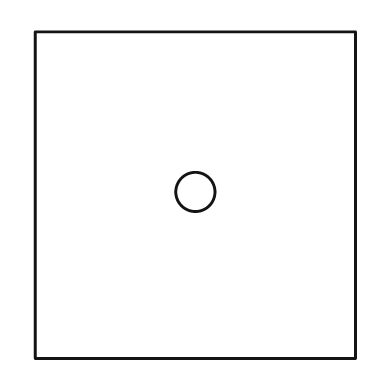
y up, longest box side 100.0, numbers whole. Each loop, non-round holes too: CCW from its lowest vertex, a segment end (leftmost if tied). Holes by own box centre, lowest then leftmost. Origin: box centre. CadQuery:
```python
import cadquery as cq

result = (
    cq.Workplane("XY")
    .moveTo(-49.0, -50.0)
    .lineTo(49.0, -50.0)
    .lineTo(49.0, 50.0)
    .lineTo(-49.0, 50.0)
    .close()
    .moveTo(0.0, 1.0)
    .circle(6.0)
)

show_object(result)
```